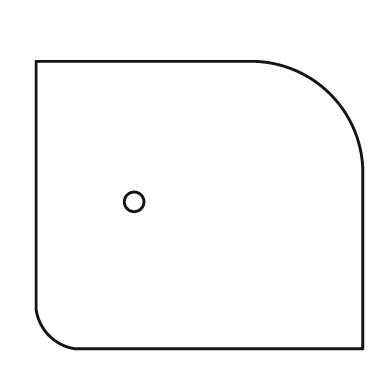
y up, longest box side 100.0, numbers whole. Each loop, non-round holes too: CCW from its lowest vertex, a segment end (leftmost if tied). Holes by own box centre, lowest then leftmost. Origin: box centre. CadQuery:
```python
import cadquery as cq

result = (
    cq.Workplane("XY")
    .moveTo(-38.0, -44.0)
    .lineTo(50.0, -44.0)
    .lineTo(50.0, 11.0)
    .threePointArc((40.0, 34.0), (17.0, 44.0))
    .lineTo(-50.0, 44.0)
    .lineTo(-50.0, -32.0)
    .threePointArc((-46.0, -40.0), (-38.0, -44.0))
    .close()
    .moveTo(-20.0, 1.0)
    .circle(3.0)
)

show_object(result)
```